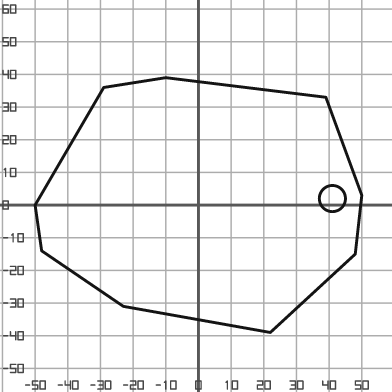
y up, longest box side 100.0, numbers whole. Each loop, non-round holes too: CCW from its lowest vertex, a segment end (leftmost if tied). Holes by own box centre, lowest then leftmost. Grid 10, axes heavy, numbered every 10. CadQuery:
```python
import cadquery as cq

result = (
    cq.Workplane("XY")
    .moveTo(22.0, -39.0)
    .lineTo(48.0, -15.0)
    .lineTo(50.0, 3.0)
    .lineTo(39.0, 33.0)
    .lineTo(-10.0, 39.0)
    .lineTo(-29.0, 36.0)
    .lineTo(-50.0, 0.0)
    .lineTo(-48.0, -14.0)
    .lineTo(-23.0, -31.0)
    .close()
    .moveTo(41.0, 2.0)
    .circle(4.0)
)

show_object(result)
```